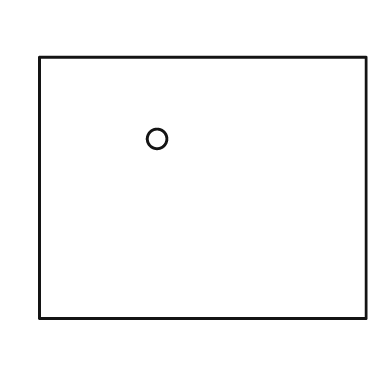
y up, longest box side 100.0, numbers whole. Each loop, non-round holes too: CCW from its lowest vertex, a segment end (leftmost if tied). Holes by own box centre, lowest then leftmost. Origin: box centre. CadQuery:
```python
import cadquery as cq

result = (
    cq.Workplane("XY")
    .moveTo(-50.0, -40.0)
    .lineTo(50.0, -40.0)
    .lineTo(50.0, 40.0)
    .lineTo(-50.0, 40.0)
    .close()
    .moveTo(-14.0, 15.0)
    .circle(3.0)
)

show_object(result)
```